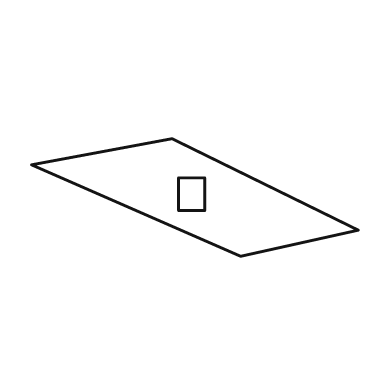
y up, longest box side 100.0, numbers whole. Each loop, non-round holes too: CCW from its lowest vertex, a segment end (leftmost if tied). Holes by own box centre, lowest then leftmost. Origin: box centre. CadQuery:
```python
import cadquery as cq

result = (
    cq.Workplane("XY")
    .moveTo(14.0, -18.0)
    .lineTo(50.0, -10.0)
    .lineTo(-7.0, 18.0)
    .lineTo(-50.0, 10.0)
    .close()
    .moveTo(-5.0, -4.0)
    .lineTo(3.0, -4.0)
    .lineTo(3.0, 6.0)
    .lineTo(-5.0, 6.0)
    .close()
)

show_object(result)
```